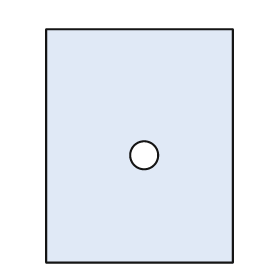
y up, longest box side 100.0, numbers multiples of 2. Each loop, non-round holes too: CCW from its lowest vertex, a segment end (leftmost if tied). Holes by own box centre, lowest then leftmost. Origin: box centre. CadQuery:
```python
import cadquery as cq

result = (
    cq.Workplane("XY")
    .moveTo(-40.0, -50.0)
    .lineTo(40.0, -50.0)
    .lineTo(40.0, 50.0)
    .lineTo(-40.0, 50.0)
    .close()
    .moveTo(2.0, -4.0)
    .circle(6.0)
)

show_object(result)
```